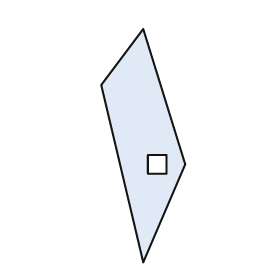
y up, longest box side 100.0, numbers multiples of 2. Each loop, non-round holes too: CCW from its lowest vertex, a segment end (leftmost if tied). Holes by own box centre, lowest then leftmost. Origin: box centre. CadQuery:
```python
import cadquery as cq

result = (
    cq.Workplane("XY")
    .moveTo(0.0, -50.0)
    .lineTo(18.0, -8.0)
    .lineTo(0.0, 50.0)
    .lineTo(-18.0, 26.0)
    .close()
    .moveTo(2.0, -12.0)
    .lineTo(10.0, -12.0)
    .lineTo(10.0, -4.0)
    .lineTo(2.0, -4.0)
    .close()
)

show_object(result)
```